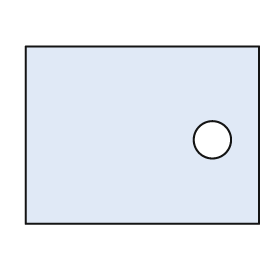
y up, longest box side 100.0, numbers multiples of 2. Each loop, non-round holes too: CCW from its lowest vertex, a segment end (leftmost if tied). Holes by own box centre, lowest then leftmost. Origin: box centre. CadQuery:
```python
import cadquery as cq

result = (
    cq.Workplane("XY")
    .moveTo(-50.0, -38.0)
    .lineTo(50.0, -38.0)
    .lineTo(50.0, 38.0)
    .lineTo(-50.0, 38.0)
    .close()
    .moveTo(30.0, -2.0)
    .circle(8.0)
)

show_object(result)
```